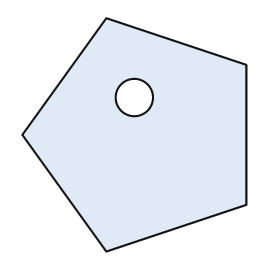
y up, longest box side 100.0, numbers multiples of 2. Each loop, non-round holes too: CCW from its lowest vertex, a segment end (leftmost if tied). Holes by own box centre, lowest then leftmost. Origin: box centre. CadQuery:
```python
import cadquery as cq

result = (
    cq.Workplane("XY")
    .moveTo(-12.0, -50.0)
    .lineTo(48.0, -30.0)
    .lineTo(48.0, 30.0)
    .lineTo(-12.0, 50.0)
    .lineTo(-48.0, 0.0)
    .close()
    .moveTo(0.0, 16.0)
    .circle(8.0)
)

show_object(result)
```